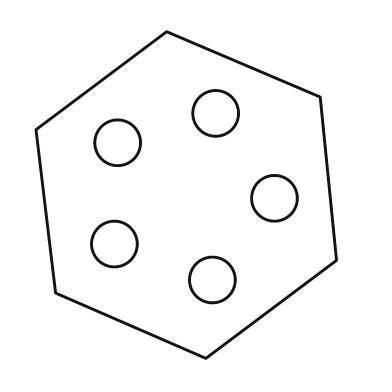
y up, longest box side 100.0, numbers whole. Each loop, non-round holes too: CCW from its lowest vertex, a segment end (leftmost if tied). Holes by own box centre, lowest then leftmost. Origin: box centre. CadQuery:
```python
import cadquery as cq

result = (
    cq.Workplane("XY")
    .moveTo(6.0, -50.0)
    .lineTo(46.0, -20.0)
    .lineTo(41.0, 30.0)
    .lineTo(-6.0, 50.0)
    .lineTo(-46.0, 20.0)
    .lineTo(-40.0, -30.0)
    .close()
    .moveTo(8.0, -26.0)
    .circle(7.0)
    .moveTo(-22.0, -15.0)
    .circle(7.0)
    .moveTo(27.0, -1.0)
    .circle(7.0)
    .moveTo(-21.0, 16.0)
    .circle(7.0)
    .moveTo(9.0, 25.0)
    .circle(7.0)
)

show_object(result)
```